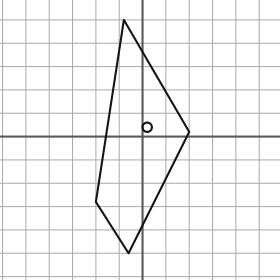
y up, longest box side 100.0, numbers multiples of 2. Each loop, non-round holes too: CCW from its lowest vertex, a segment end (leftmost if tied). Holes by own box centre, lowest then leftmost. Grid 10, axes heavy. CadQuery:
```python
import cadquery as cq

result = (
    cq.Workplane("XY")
    .moveTo(-6.0, -50.0)
    .lineTo(20.0, 2.0)
    .lineTo(-8.0, 50.0)
    .lineTo(-20.0, -28.0)
    .close()
    .moveTo(2.0, 4.0)
    .circle(2.0)
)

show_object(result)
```